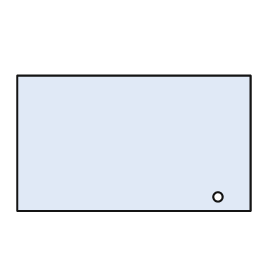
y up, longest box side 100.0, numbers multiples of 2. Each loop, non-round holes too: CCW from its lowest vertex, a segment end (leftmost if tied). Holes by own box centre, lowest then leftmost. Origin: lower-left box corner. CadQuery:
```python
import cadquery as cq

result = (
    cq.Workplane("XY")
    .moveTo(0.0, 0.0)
    .lineTo(100.0, 0.0)
    .lineTo(100.0, 58.0)
    .lineTo(0.0, 58.0)
    .close()
    .moveTo(86.0, 6.0)
    .circle(2.0)
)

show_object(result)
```